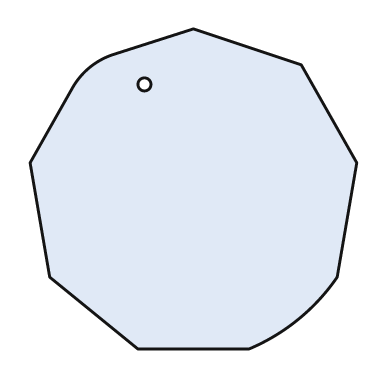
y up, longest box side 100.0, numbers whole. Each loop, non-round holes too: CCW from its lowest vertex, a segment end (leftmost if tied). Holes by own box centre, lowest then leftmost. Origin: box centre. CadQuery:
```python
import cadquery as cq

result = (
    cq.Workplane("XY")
    .moveTo(-17.0, -49.0)
    .lineTo(17.0, -49.0)
    .threePointArc((32.0, -40.0), (44.0, -27.0))
    .lineTo(50.0, 8.0)
    .lineTo(33.0, 38.0)
    .lineTo(0.0, 49.0)
    .lineTo(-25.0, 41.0)
    .threePointArc((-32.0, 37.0), (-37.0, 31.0))
    .lineTo(-50.0, 8.0)
    .lineTo(-44.0, -27.0)
    .close()
    .moveTo(-15.0, 32.0)
    .circle(2.0)
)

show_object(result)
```